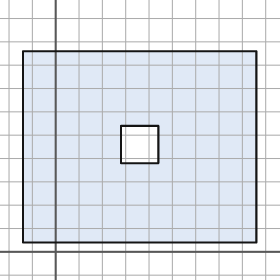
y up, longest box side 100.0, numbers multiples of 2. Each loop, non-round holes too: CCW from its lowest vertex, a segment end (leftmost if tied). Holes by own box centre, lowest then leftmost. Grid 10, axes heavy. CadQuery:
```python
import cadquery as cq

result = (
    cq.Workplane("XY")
    .moveTo(-14.0, 4.0)
    .lineTo(86.0, 4.0)
    .lineTo(86.0, 86.0)
    .lineTo(-14.0, 86.0)
    .close()
    .moveTo(28.0, 38.0)
    .lineTo(44.0, 38.0)
    .lineTo(44.0, 54.0)
    .lineTo(28.0, 54.0)
    .close()
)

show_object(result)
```